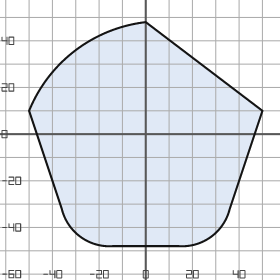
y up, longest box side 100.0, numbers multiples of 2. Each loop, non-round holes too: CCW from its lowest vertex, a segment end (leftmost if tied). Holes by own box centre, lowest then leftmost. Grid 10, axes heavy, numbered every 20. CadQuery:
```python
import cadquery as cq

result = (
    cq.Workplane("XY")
    .moveTo(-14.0, -48.0)
    .lineTo(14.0, -48.0)
    .threePointArc((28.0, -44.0), (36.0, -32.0))
    .lineTo(50.0, 10.0)
    .lineTo(0.0, 48.0)
    .threePointArc((-30.0, 36.0), (-50.0, 10.0))
    .lineTo(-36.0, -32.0)
    .threePointArc((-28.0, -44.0), (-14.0, -48.0))
    .close()
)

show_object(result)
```